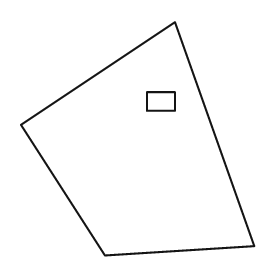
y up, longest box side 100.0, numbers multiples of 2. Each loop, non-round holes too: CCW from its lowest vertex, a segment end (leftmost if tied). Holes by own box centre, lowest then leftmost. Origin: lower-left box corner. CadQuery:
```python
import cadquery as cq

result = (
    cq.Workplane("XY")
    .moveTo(36.0, 0.0)
    .lineTo(100.0, 4.0)
    .lineTo(66.0, 100.0)
    .lineTo(0.0, 56.0)
    .close()
    .moveTo(54.0, 62.0)
    .lineTo(66.0, 62.0)
    .lineTo(66.0, 70.0)
    .lineTo(54.0, 70.0)
    .close()
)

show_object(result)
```